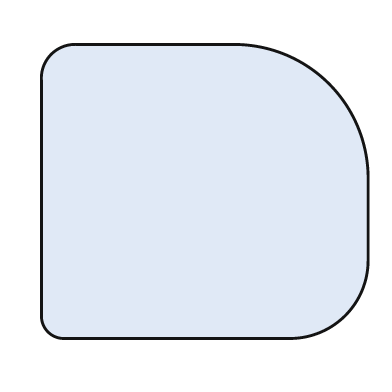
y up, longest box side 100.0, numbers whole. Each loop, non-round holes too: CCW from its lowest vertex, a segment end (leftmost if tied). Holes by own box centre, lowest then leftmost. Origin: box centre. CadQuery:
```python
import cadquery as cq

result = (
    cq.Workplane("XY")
    .moveTo(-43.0, -45.0)
    .lineTo(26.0, -45.0)
    .threePointArc((43.0, -38.0), (50.0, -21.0))
    .lineTo(50.0, 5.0)
    .threePointArc((38.0, 33.0), (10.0, 45.0))
    .lineTo(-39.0, 45.0)
    .threePointArc((-47.0, 42.0), (-50.0, 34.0))
    .lineTo(-50.0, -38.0)
    .threePointArc((-48.0, -43.0), (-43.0, -45.0))
    .close()
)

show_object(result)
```